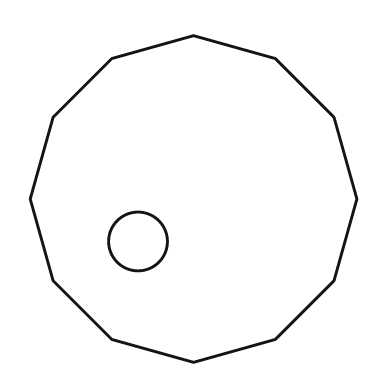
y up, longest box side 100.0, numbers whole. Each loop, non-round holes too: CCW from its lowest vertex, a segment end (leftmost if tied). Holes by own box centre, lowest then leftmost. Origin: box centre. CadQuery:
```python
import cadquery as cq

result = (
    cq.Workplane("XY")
    .moveTo(0.0, -50.0)
    .lineTo(25.0, -43.0)
    .lineTo(43.0, -25.0)
    .lineTo(50.0, 0.0)
    .lineTo(43.0, 25.0)
    .lineTo(25.0, 43.0)
    .lineTo(0.0, 50.0)
    .lineTo(-25.0, 43.0)
    .lineTo(-43.0, 25.0)
    .lineTo(-50.0, 0.0)
    .lineTo(-43.0, -25.0)
    .lineTo(-25.0, -43.0)
    .close()
    .moveTo(-17.0, -13.0)
    .circle(9.0)
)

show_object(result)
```